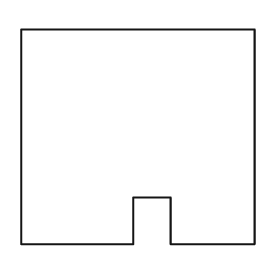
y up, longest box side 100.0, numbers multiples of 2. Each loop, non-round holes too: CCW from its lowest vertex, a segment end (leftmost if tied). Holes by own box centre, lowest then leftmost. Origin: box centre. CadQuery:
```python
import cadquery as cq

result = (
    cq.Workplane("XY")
    .moveTo(-50.0, -46.0)
    .lineTo(-2.0, -46.0)
    .lineTo(-2.0, -26.0)
    .lineTo(14.0, -26.0)
    .lineTo(14.0, -46.0)
    .lineTo(50.0, -46.0)
    .lineTo(50.0, 46.0)
    .lineTo(-50.0, 46.0)
    .close()
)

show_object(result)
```